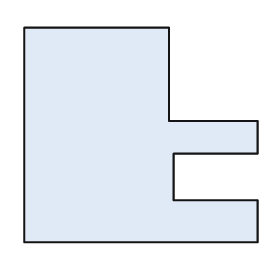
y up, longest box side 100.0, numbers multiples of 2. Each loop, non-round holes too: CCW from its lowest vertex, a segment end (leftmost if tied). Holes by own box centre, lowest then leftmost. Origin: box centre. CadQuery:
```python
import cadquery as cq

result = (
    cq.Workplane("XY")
    .moveTo(-50.0, -46.0)
    .lineTo(50.0, -46.0)
    .lineTo(50.0, -28.0)
    .lineTo(14.0, -28.0)
    .lineTo(14.0, -8.0)
    .lineTo(50.0, -8.0)
    .lineTo(50.0, 6.0)
    .lineTo(12.0, 6.0)
    .lineTo(12.0, 46.0)
    .lineTo(-50.0, 46.0)
    .close()
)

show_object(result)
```